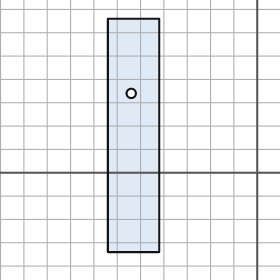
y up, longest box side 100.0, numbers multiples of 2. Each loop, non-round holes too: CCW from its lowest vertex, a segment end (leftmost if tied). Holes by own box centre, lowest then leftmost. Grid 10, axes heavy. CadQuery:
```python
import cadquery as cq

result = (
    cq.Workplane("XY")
    .moveTo(-64.0, -34.0)
    .lineTo(-42.0, -34.0)
    .lineTo(-42.0, 66.0)
    .lineTo(-64.0, 66.0)
    .close()
    .moveTo(-54.0, 34.0)
    .circle(2.0)
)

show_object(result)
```